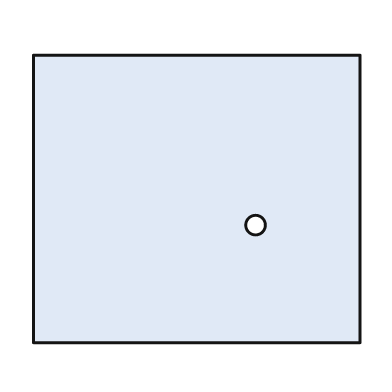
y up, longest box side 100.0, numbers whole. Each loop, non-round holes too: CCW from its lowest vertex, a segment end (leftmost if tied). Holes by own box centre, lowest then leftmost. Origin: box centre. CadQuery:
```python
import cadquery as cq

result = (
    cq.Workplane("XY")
    .moveTo(-50.0, -44.0)
    .lineTo(50.0, -44.0)
    .lineTo(50.0, 44.0)
    .lineTo(-50.0, 44.0)
    .close()
    .moveTo(18.0, -8.0)
    .circle(3.0)
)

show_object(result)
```